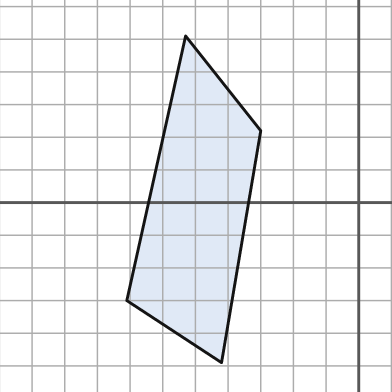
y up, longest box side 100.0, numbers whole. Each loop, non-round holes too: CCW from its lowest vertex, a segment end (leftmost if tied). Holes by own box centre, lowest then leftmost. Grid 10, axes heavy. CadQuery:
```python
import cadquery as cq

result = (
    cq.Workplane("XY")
    .moveTo(-42.0, -49.0)
    .lineTo(-30.0, 22.0)
    .lineTo(-53.0, 51.0)
    .lineTo(-71.0, -30.0)
    .close()
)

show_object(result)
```